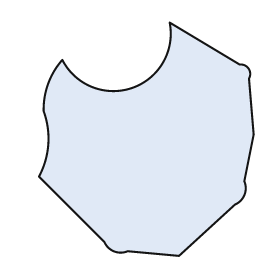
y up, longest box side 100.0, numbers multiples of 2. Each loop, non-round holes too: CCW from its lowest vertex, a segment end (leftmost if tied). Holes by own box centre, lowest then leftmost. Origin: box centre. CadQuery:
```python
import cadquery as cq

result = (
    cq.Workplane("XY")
    .moveTo(14.0, -50.0)
    .lineTo(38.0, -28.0)
    .threePointArc((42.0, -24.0), (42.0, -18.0))
    .lineTo(46.0, 2.0)
    .lineTo(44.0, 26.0)
    .threePointArc((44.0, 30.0), (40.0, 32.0))
    .lineTo(10.0, 50.0)
    .threePointArc((-6.0, 22.0), (-36.0, 34.0))
    .threePointArc((-42.0, 24.0), (-44.0, 12.0))
    .threePointArc((-42.0, -2.0), (-46.0, -16.0))
    .lineTo(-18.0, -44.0)
    .threePointArc((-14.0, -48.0), (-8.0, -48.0))
    .close()
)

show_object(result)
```